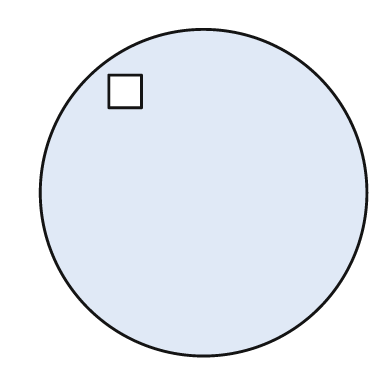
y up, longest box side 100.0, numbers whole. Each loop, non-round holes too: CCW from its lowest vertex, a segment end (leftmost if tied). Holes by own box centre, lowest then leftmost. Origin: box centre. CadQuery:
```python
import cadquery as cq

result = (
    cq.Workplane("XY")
    .moveTo(0.0, 0.0)
    .circle(50.0)
    .moveTo(-29.0, 26.0)
    .lineTo(-19.0, 26.0)
    .lineTo(-19.0, 36.0)
    .lineTo(-29.0, 36.0)
    .close()
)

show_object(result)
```